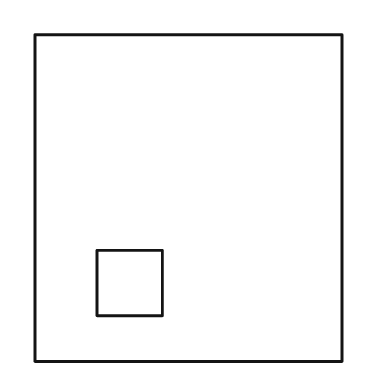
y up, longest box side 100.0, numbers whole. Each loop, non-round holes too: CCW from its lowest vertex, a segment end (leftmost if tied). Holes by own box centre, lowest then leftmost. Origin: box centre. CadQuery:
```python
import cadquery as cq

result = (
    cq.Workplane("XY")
    .moveTo(-47.0, -50.0)
    .lineTo(47.0, -50.0)
    .lineTo(47.0, 50.0)
    .lineTo(-47.0, 50.0)
    .close()
    .moveTo(-28.0, -36.0)
    .lineTo(-8.0, -36.0)
    .lineTo(-8.0, -16.0)
    .lineTo(-28.0, -16.0)
    .close()
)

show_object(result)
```